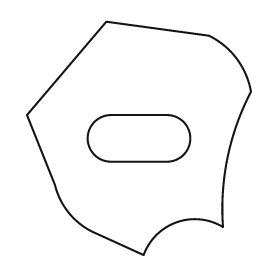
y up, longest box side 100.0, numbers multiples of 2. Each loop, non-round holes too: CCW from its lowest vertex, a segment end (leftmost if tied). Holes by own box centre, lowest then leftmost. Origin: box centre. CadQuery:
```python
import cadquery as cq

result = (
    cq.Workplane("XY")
    .moveTo(2.0, -50.0)
    .threePointArc((16.0, -36.0), (36.0, -38.0))
    .threePointArc((38.0, -8.0), (48.0, 20.0))
    .threePointArc((42.0, 34.0), (30.0, 44.0))
    .lineTo(-14.0, 50.0)
    .lineTo(-48.0, 10.0)
    .lineTo(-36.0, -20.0)
    .threePointArc((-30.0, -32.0), (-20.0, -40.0))
    .close()
    .moveTo(-12.0, -10.0)
    .lineTo(12.0, -10.0)
    .threePointArc((22.0, 0.0), (12.0, 10.0))
    .lineTo(-12.0, 10.0)
    .threePointArc((-22.0, 0.0), (-12.0, -10.0))
    .close()
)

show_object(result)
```